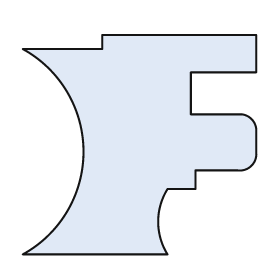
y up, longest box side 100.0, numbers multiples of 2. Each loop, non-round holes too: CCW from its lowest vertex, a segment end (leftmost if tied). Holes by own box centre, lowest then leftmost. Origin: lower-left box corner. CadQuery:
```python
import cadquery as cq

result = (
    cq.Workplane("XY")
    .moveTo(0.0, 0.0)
    .lineTo(62.0, 0.0)
    .threePointArc((58.0, 14.0), (62.0, 28.0))
    .lineTo(74.0, 28.0)
    .lineTo(74.0, 36.0)
    .lineTo(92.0, 36.0)
    .threePointArc((98.0, 38.0), (100.0, 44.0))
    .lineTo(100.0, 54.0)
    .threePointArc((98.0, 58.0), (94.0, 60.0))
    .lineTo(72.0, 60.0)
    .lineTo(72.0, 78.0)
    .lineTo(100.0, 78.0)
    .lineTo(100.0, 94.0)
    .lineTo(34.0, 94.0)
    .lineTo(34.0, 88.0)
    .lineTo(0.0, 88.0)
    .threePointArc((26.0, 44.0), (0.0, 0.0))
    .close()
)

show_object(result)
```